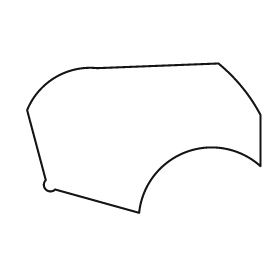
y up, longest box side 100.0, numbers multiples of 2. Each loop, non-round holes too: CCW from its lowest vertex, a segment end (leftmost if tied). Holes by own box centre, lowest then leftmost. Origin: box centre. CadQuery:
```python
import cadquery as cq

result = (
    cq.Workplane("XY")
    .moveTo(-2.0, -32.0)
    .threePointArc((18.0, -6.0), (50.0, -12.0))
    .lineTo(50.0, 10.0)
    .threePointArc((42.0, 22.0), (32.0, 32.0))
    .lineTo(-20.0, 30.0)
    .threePointArc((-38.0, 26.0), (-50.0, 12.0))
    .lineTo(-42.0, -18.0)
    .threePointArc((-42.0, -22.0), (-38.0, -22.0))
    .close()
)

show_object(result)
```